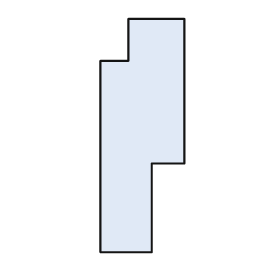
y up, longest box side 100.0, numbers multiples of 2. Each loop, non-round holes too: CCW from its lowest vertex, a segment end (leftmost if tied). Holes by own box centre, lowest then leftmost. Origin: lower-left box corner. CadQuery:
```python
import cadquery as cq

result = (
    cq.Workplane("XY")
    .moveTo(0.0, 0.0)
    .lineTo(22.0, 0.0)
    .lineTo(22.0, 38.0)
    .lineTo(36.0, 38.0)
    .lineTo(36.0, 100.0)
    .lineTo(12.0, 100.0)
    .lineTo(12.0, 82.0)
    .lineTo(0.0, 82.0)
    .close()
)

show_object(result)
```